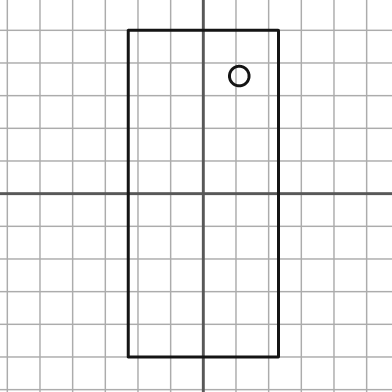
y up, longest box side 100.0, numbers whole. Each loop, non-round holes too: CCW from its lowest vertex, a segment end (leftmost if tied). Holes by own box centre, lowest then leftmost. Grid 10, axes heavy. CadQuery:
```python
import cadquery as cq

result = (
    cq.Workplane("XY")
    .moveTo(-23.0, -50.0)
    .lineTo(23.0, -50.0)
    .lineTo(23.0, 50.0)
    .lineTo(-23.0, 50.0)
    .close()
    .moveTo(11.0, 36.0)
    .circle(3.0)
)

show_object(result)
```